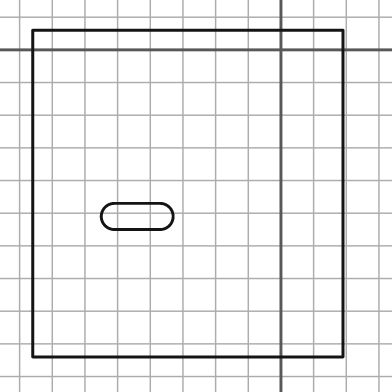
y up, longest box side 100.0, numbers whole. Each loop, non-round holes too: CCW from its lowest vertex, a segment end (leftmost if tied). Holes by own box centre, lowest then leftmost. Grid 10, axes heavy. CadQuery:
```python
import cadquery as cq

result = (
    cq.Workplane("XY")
    .moveTo(-76.0, -94.0)
    .lineTo(19.0, -94.0)
    .lineTo(19.0, 6.0)
    .lineTo(-76.0, 6.0)
    .close()
    .moveTo(-51.0, -55.0)
    .lineTo(-37.0, -55.0)
    .threePointArc((-33.0, -51.0), (-37.0, -47.0))
    .lineTo(-51.0, -47.0)
    .threePointArc((-55.0, -51.0), (-51.0, -55.0))
    .close()
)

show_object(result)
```